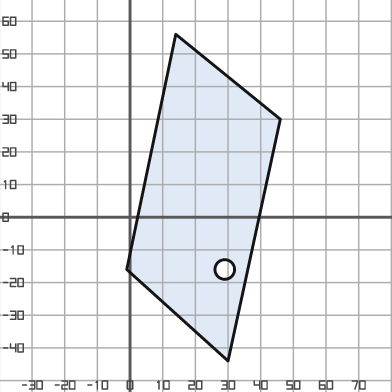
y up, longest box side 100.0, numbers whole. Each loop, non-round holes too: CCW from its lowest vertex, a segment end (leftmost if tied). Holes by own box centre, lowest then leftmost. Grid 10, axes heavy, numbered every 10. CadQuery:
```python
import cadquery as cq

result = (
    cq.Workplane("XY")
    .moveTo(30.0, -44.0)
    .lineTo(46.0, 30.0)
    .lineTo(14.0, 56.0)
    .lineTo(-1.0, -16.0)
    .close()
    .moveTo(29.0, -16.0)
    .circle(3.0)
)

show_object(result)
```